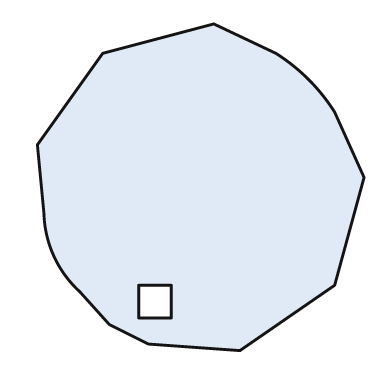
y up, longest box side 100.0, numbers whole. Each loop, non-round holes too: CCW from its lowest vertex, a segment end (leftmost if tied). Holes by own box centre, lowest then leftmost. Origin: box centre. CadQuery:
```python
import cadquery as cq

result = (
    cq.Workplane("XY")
    .moveTo(12.0, -50.0)
    .lineTo(41.0, -30.0)
    .lineTo(50.0, 3.0)
    .lineTo(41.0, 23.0)
    .threePointArc((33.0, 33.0), (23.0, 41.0))
    .lineTo(4.0, 50.0)
    .lineTo(-30.0, 41.0)
    .lineTo(-50.0, 13.0)
    .lineTo(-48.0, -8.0)
    .threePointArc((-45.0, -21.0), (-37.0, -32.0))
    .lineTo(-28.0, -42.0)
    .lineTo(-16.0, -48.0)
    .close()
    .moveTo(-19.0, -40.0)
    .lineTo(-9.0, -40.0)
    .lineTo(-9.0, -30.0)
    .lineTo(-19.0, -30.0)
    .close()
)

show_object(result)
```